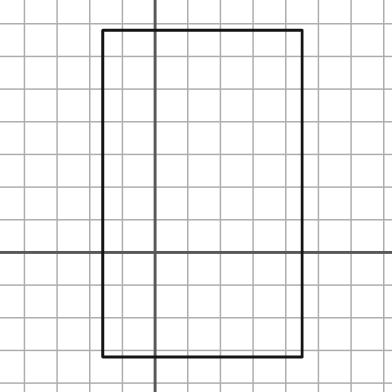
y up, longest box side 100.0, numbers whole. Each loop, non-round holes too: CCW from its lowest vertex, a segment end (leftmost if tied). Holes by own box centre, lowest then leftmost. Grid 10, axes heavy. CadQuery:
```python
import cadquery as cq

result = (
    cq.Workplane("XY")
    .moveTo(-16.0, -32.0)
    .lineTo(45.0, -32.0)
    .lineTo(45.0, 68.0)
    .lineTo(-16.0, 68.0)
    .close()
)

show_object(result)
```